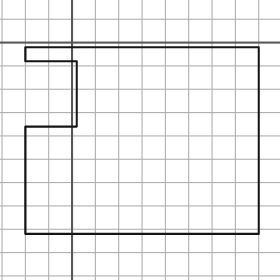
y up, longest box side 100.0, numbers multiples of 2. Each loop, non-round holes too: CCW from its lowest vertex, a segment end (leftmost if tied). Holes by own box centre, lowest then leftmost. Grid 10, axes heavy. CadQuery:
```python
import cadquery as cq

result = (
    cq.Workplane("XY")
    .moveTo(-20.0, -82.0)
    .lineTo(80.0, -82.0)
    .lineTo(80.0, -2.0)
    .lineTo(-20.0, -2.0)
    .lineTo(-20.0, -8.0)
    .lineTo(2.0, -8.0)
    .lineTo(2.0, -36.0)
    .lineTo(-20.0, -36.0)
    .close()
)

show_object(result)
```